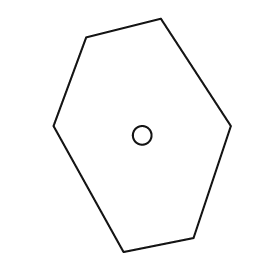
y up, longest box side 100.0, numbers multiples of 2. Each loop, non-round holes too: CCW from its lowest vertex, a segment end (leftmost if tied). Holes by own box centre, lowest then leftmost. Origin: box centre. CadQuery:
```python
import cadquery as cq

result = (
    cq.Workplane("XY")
    .moveTo(-8.0, -50.0)
    .lineTo(22.0, -44.0)
    .lineTo(38.0, 4.0)
    .lineTo(8.0, 50.0)
    .lineTo(-24.0, 42.0)
    .lineTo(-38.0, 4.0)
    .close()
    .moveTo(0.0, 0.0)
    .circle(4.0)
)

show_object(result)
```